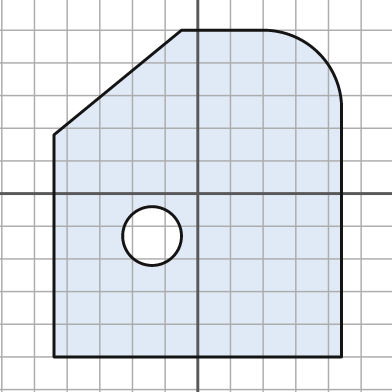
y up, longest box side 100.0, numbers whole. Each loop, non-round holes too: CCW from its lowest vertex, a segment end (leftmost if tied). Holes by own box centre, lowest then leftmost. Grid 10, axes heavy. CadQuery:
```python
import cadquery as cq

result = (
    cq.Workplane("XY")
    .moveTo(-44.0, -50.0)
    .lineTo(44.0, -50.0)
    .lineTo(44.0, 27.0)
    .threePointArc((37.0, 43.0), (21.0, 50.0))
    .lineTo(-5.0, 50.0)
    .lineTo(-44.0, 18.0)
    .close()
    .moveTo(-14.0, -13.0)
    .circle(9.0)
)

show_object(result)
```